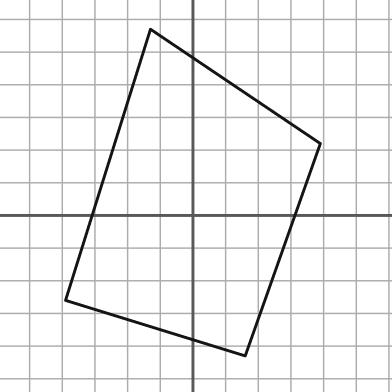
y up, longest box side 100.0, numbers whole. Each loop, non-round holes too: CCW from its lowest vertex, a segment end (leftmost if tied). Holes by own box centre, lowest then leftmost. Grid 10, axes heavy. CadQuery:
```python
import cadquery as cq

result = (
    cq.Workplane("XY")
    .moveTo(16.0, -43.0)
    .lineTo(39.0, 22.0)
    .lineTo(-13.0, 57.0)
    .lineTo(-39.0, -26.0)
    .close()
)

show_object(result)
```